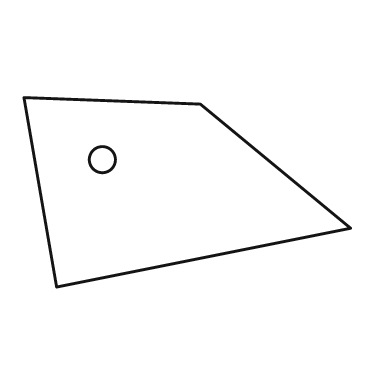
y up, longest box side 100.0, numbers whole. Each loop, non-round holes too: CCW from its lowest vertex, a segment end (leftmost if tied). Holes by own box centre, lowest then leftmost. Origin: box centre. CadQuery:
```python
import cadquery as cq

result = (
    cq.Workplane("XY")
    .moveTo(-40.0, -29.0)
    .lineTo(50.0, -11.0)
    .lineTo(4.0, 27.0)
    .lineTo(-50.0, 29.0)
    .close()
    .moveTo(-26.0, 10.0)
    .circle(4.0)
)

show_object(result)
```